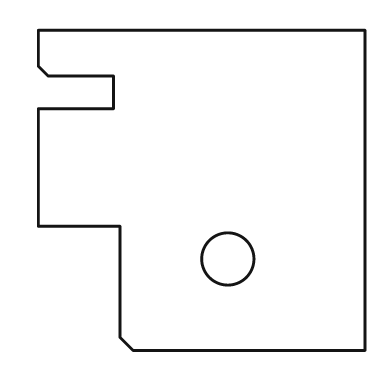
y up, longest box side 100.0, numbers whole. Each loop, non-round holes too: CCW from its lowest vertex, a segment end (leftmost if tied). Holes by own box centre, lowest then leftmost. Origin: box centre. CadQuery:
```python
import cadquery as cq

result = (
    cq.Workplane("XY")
    .moveTo(-21.0, -49.0)
    .lineTo(50.0, -49.0)
    .lineTo(50.0, 49.0)
    .lineTo(-50.0, 49.0)
    .lineTo(-50.0, 38.0)
    .lineTo(-47.0, 35.0)
    .lineTo(-27.0, 35.0)
    .lineTo(-27.0, 25.0)
    .lineTo(-50.0, 25.0)
    .lineTo(-50.0, -11.0)
    .lineTo(-25.0, -11.0)
    .lineTo(-25.0, -45.0)
    .close()
    .moveTo(8.0, -21.0)
    .circle(8.0)
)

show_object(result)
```